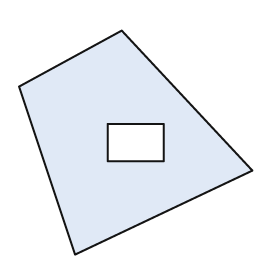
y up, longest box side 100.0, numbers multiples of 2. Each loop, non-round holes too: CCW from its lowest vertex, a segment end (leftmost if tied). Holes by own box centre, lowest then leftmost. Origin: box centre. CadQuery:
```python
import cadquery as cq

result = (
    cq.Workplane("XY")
    .moveTo(-26.0, -48.0)
    .lineTo(50.0, -12.0)
    .lineTo(-6.0, 48.0)
    .lineTo(-50.0, 24.0)
    .close()
    .moveTo(-12.0, -8.0)
    .lineTo(12.0, -8.0)
    .lineTo(12.0, 8.0)
    .lineTo(-12.0, 8.0)
    .close()
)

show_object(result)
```